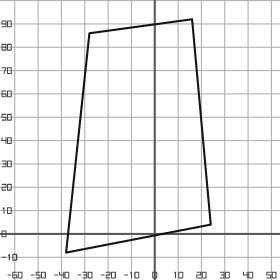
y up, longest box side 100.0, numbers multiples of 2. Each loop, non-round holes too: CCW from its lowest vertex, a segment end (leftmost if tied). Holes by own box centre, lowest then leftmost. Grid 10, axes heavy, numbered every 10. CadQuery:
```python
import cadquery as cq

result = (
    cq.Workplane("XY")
    .moveTo(-38.0, -8.0)
    .lineTo(24.0, 4.0)
    .lineTo(16.0, 92.0)
    .lineTo(-28.0, 86.0)
    .close()
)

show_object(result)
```